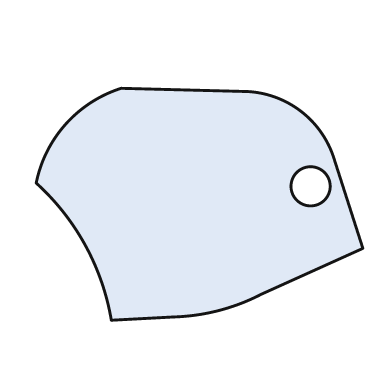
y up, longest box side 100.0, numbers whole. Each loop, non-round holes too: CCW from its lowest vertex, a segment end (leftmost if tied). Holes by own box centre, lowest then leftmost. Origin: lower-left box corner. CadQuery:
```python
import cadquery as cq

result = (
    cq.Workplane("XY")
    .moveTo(23.0, 0.0)
    .lineTo(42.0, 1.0)
    .threePointArc((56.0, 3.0), (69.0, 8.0))
    .lineTo(100.0, 22.0)
    .lineTo(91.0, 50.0)
    .threePointArc((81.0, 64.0), (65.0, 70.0))
    .lineTo(26.0, 71.0)
    .threePointArc((9.0, 60.0), (0.0, 42.0))
    .threePointArc((15.0, 23.0), (23.0, 0.0))
    .close()
    .moveTo(84.0, 41.0)
    .circle(6.0)
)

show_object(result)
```